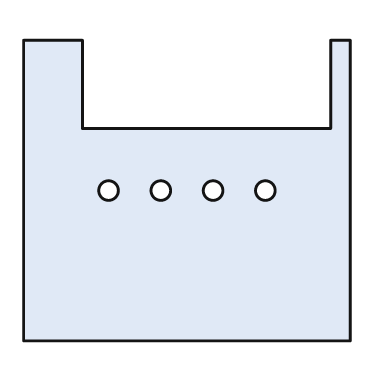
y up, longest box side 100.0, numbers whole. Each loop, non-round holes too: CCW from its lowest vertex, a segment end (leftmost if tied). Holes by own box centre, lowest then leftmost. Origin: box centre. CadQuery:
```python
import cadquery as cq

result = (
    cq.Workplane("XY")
    .moveTo(-50.0, -46.0)
    .lineTo(50.0, -46.0)
    .lineTo(50.0, 46.0)
    .lineTo(44.0, 46.0)
    .lineTo(44.0, 19.0)
    .lineTo(-32.0, 19.0)
    .lineTo(-32.0, 46.0)
    .lineTo(-50.0, 46.0)
    .close()
    .moveTo(-24.0, 0.0)
    .circle(3.0)
    .moveTo(-8.0, 0.0)
    .circle(3.0)
    .moveTo(8.0, 0.0)
    .circle(3.0)
    .moveTo(24.0, 0.0)
    .circle(3.0)
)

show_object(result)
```